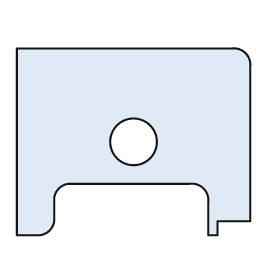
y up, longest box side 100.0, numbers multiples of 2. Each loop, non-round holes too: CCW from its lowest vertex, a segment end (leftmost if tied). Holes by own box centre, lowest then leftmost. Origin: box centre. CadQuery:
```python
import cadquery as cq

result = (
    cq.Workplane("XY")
    .moveTo(-50.0, -40.0)
    .lineTo(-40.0, -40.0)
    .threePointArc((-36.0, -38.0), (-34.0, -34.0))
    .lineTo(-34.0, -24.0)
    .threePointArc((-32.0, -20.0), (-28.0, -18.0))
    .lineTo(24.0, -18.0)
    .threePointArc((30.0, -20.0), (32.0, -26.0))
    .lineTo(32.0, -40.0)
    .lineTo(36.0, -40.0)
    .lineTo(36.0, -34.0)
    .lineTo(50.0, -34.0)
    .lineTo(50.0, 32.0)
    .threePointArc((48.0, 38.0), (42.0, 40.0))
    .lineTo(-50.0, 40.0)
    .close()
    .moveTo(0.0, 0.0)
    .circle(10.0)
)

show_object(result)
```